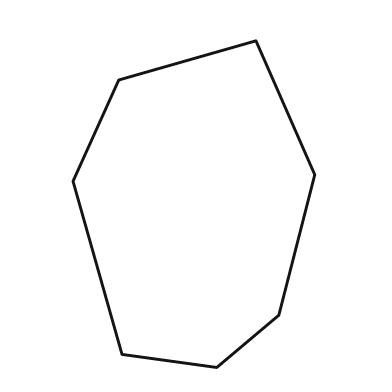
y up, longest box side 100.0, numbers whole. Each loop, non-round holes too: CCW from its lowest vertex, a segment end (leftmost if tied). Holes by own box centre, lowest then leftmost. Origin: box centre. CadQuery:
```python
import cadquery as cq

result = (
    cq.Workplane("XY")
    .moveTo(7.0, -50.0)
    .lineTo(26.0, -34.0)
    .lineTo(37.0, 9.0)
    .lineTo(19.0, 50.0)
    .lineTo(-23.0, 38.0)
    .lineTo(-37.0, 7.0)
    .lineTo(-22.0, -46.0)
    .close()
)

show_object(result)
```